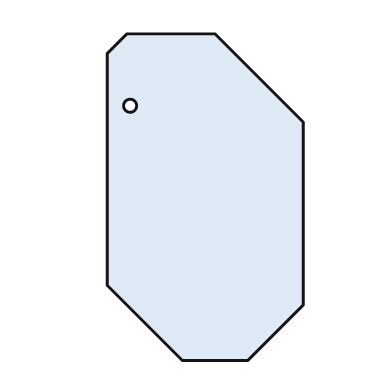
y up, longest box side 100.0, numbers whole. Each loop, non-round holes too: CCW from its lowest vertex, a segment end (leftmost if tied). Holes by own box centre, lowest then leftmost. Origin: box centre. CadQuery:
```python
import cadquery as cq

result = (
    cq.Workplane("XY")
    .moveTo(-7.0, -50.0)
    .lineTo(13.0, -50.0)
    .lineTo(30.0, -33.0)
    .lineTo(30.0, 23.0)
    .lineTo(3.0, 50.0)
    .lineTo(-24.0, 50.0)
    .lineTo(-30.0, 44.0)
    .lineTo(-30.0, -27.0)
    .close()
    .moveTo(-23.0, 28.0)
    .circle(2.0)
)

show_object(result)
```